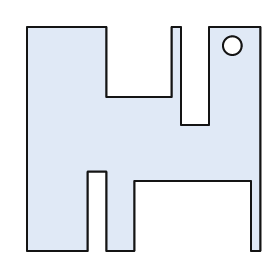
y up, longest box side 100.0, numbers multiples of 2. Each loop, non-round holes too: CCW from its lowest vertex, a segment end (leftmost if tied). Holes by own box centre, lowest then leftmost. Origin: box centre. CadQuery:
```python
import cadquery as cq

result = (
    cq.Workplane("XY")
    .moveTo(-50.0, -48.0)
    .lineTo(-24.0, -48.0)
    .lineTo(-24.0, -14.0)
    .lineTo(-16.0, -14.0)
    .lineTo(-16.0, -48.0)
    .lineTo(-4.0, -48.0)
    .lineTo(-4.0, -18.0)
    .lineTo(46.0, -18.0)
    .lineTo(46.0, -48.0)
    .lineTo(50.0, -48.0)
    .lineTo(50.0, 48.0)
    .lineTo(28.0, 48.0)
    .lineTo(28.0, 6.0)
    .lineTo(16.0, 6.0)
    .lineTo(16.0, 48.0)
    .lineTo(12.0, 48.0)
    .lineTo(12.0, 18.0)
    .lineTo(-16.0, 18.0)
    .lineTo(-16.0, 48.0)
    .lineTo(-50.0, 48.0)
    .close()
    .moveTo(38.0, 40.0)
    .circle(4.0)
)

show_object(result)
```